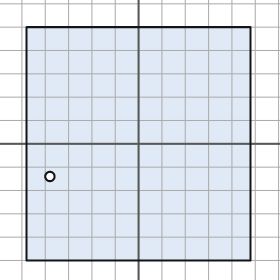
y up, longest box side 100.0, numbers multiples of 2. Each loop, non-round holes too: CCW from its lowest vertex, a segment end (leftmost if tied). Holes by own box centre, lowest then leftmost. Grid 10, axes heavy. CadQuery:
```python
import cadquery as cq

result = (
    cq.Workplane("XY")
    .moveTo(-48.0, -50.0)
    .lineTo(48.0, -50.0)
    .lineTo(48.0, 50.0)
    .lineTo(-48.0, 50.0)
    .close()
    .moveTo(-38.0, -14.0)
    .circle(2.0)
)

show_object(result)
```